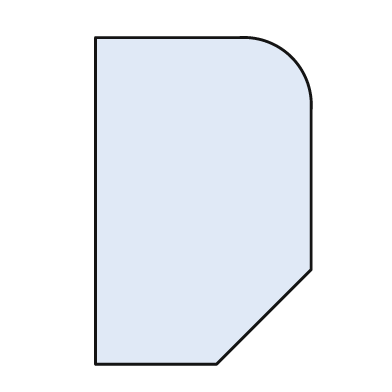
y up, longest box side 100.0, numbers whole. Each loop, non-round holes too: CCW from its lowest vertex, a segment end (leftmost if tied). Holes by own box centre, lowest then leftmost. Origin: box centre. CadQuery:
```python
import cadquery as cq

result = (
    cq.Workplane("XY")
    .moveTo(-33.0, -50.0)
    .lineTo(4.0, -50.0)
    .lineTo(33.0, -21.0)
    .lineTo(33.0, 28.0)
    .threePointArc((27.0, 44.0), (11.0, 50.0))
    .lineTo(-33.0, 50.0)
    .close()
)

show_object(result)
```